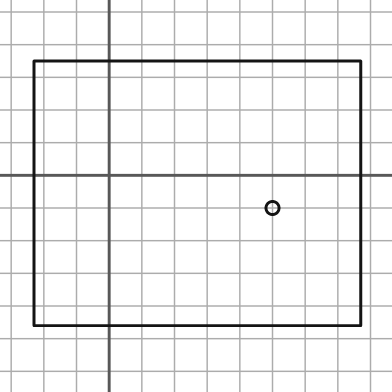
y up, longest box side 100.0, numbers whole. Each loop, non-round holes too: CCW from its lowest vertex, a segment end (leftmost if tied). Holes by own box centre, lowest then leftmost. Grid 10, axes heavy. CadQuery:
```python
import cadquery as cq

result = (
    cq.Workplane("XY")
    .moveTo(-23.0, -46.0)
    .lineTo(77.0, -46.0)
    .lineTo(77.0, 35.0)
    .lineTo(-23.0, 35.0)
    .close()
    .moveTo(50.0, -10.0)
    .circle(2.0)
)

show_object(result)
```